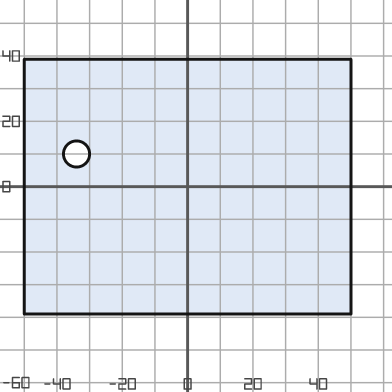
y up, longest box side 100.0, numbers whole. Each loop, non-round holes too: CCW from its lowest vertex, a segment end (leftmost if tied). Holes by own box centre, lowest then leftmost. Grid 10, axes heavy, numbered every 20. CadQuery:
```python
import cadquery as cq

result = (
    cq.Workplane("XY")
    .moveTo(-50.0, -39.0)
    .lineTo(50.0, -39.0)
    .lineTo(50.0, 39.0)
    .lineTo(-50.0, 39.0)
    .close()
    .moveTo(-34.0, 10.0)
    .circle(4.0)
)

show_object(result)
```